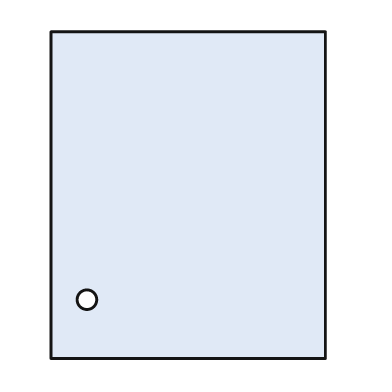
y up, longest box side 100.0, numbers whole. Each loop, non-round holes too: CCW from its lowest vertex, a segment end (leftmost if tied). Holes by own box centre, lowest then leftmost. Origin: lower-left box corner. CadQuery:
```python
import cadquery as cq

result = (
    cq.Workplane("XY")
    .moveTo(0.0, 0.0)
    .lineTo(84.0, 0.0)
    .lineTo(84.0, 100.0)
    .lineTo(0.0, 100.0)
    .close()
    .moveTo(11.0, 18.0)
    .circle(3.0)
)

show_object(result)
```